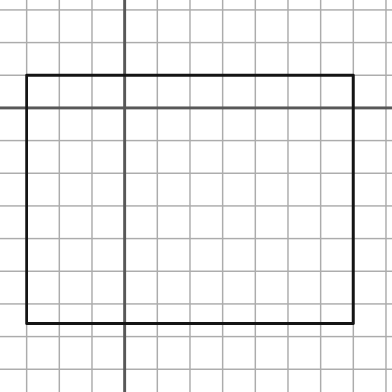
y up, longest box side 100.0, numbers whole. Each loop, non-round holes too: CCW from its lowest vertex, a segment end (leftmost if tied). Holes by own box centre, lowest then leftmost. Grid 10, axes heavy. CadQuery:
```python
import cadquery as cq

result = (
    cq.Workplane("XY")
    .moveTo(-30.0, -66.0)
    .lineTo(70.0, -66.0)
    .lineTo(70.0, 10.0)
    .lineTo(-30.0, 10.0)
    .close()
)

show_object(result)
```